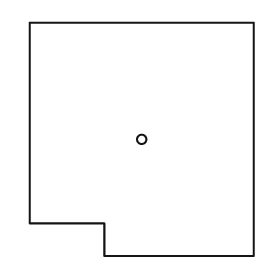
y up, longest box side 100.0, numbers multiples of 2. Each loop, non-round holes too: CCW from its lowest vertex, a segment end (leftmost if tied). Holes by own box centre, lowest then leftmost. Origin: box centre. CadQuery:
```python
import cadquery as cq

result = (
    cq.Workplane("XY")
    .moveTo(-16.0, -50.0)
    .lineTo(48.0, -50.0)
    .lineTo(48.0, 50.0)
    .lineTo(-48.0, 50.0)
    .lineTo(-48.0, -36.0)
    .lineTo(-16.0, -36.0)
    .close()
    .moveTo(0.0, 0.0)
    .circle(2.0)
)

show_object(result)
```